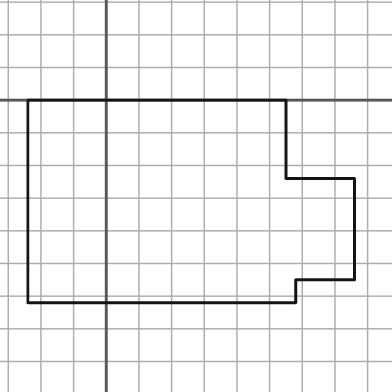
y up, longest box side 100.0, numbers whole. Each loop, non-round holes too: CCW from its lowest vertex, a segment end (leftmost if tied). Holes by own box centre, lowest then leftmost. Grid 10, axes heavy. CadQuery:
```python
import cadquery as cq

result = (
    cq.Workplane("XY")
    .moveTo(-24.0, -62.0)
    .lineTo(58.0, -62.0)
    .lineTo(58.0, -55.0)
    .lineTo(76.0, -55.0)
    .lineTo(76.0, -24.0)
    .lineTo(55.0, -24.0)
    .lineTo(55.0, 0.0)
    .lineTo(-24.0, 0.0)
    .close()
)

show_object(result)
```